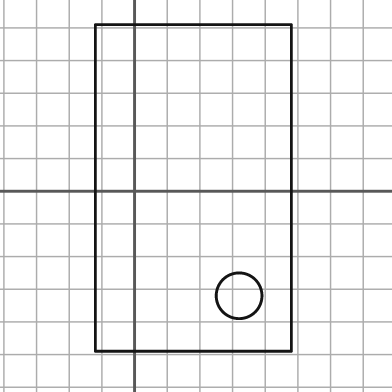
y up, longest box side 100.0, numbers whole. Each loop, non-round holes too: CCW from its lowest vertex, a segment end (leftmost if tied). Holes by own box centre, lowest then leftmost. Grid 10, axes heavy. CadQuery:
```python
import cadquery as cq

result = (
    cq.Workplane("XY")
    .moveTo(-12.0, -49.0)
    .lineTo(48.0, -49.0)
    .lineTo(48.0, 51.0)
    .lineTo(-12.0, 51.0)
    .close()
    .moveTo(32.0, -32.0)
    .circle(7.0)
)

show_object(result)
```